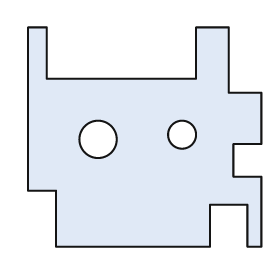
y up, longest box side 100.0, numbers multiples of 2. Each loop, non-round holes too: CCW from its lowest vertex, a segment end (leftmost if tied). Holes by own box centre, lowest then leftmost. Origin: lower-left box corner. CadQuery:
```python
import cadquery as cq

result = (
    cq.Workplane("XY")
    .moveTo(12.0, 0.0)
    .lineTo(78.0, 0.0)
    .lineTo(78.0, 18.0)
    .lineTo(94.0, 18.0)
    .lineTo(94.0, 0.0)
    .lineTo(100.0, 0.0)
    .lineTo(100.0, 30.0)
    .lineTo(88.0, 30.0)
    .lineTo(88.0, 44.0)
    .lineTo(100.0, 44.0)
    .lineTo(100.0, 66.0)
    .lineTo(86.0, 66.0)
    .lineTo(86.0, 94.0)
    .lineTo(72.0, 94.0)
    .lineTo(72.0, 72.0)
    .lineTo(8.0, 72.0)
    .lineTo(8.0, 94.0)
    .lineTo(0.0, 94.0)
    .lineTo(0.0, 24.0)
    .lineTo(12.0, 24.0)
    .close()
    .moveTo(30.0, 46.0)
    .circle(8.0)
    .moveTo(66.0, 48.0)
    .circle(6.0)
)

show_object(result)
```